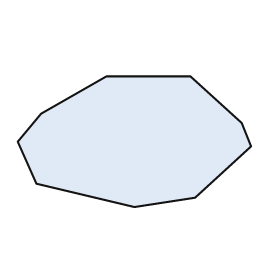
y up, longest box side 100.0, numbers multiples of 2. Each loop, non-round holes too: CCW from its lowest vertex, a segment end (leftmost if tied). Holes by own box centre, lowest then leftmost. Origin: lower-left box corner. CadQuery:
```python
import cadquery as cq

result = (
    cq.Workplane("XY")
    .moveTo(50.0, 0.0)
    .lineTo(76.0, 4.0)
    .lineTo(100.0, 26.0)
    .lineTo(96.0, 36.0)
    .lineTo(74.0, 56.0)
    .lineTo(38.0, 56.0)
    .lineTo(10.0, 40.0)
    .lineTo(0.0, 28.0)
    .lineTo(8.0, 10.0)
    .close()
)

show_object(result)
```